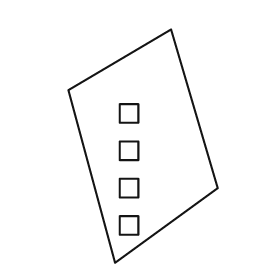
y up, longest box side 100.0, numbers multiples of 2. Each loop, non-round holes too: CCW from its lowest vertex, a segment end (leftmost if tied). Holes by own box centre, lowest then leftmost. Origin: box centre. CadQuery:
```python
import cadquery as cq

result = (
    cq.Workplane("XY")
    .moveTo(-12.0, -50.0)
    .lineTo(32.0, -18.0)
    .lineTo(12.0, 50.0)
    .lineTo(-32.0, 24.0)
    .close()
    .moveTo(-10.0, -38.0)
    .lineTo(-2.0, -38.0)
    .lineTo(-2.0, -30.0)
    .lineTo(-10.0, -30.0)
    .close()
    .moveTo(-10.0, -22.0)
    .lineTo(-2.0, -22.0)
    .lineTo(-2.0, -14.0)
    .lineTo(-10.0, -14.0)
    .close()
    .moveTo(-10.0, -6.0)
    .lineTo(-2.0, -6.0)
    .lineTo(-2.0, 2.0)
    .lineTo(-10.0, 2.0)
    .close()
    .moveTo(-10.0, 10.0)
    .lineTo(-2.0, 10.0)
    .lineTo(-2.0, 18.0)
    .lineTo(-10.0, 18.0)
    .close()
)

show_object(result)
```